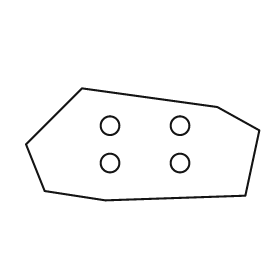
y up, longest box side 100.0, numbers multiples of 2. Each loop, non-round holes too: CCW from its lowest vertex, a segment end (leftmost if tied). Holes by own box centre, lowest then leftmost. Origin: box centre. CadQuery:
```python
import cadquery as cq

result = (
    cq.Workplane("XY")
    .moveTo(-16.0, -24.0)
    .lineTo(44.0, -22.0)
    .lineTo(50.0, 6.0)
    .lineTo(32.0, 16.0)
    .lineTo(-26.0, 24.0)
    .lineTo(-50.0, 0.0)
    .lineTo(-42.0, -20.0)
    .close()
    .moveTo(-14.0, -8.0)
    .circle(4.0)
    .moveTo(16.0, -8.0)
    .circle(4.0)
    .moveTo(-14.0, 8.0)
    .circle(4.0)
    .moveTo(16.0, 8.0)
    .circle(4.0)
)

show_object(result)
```